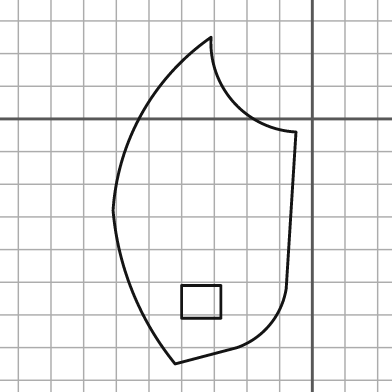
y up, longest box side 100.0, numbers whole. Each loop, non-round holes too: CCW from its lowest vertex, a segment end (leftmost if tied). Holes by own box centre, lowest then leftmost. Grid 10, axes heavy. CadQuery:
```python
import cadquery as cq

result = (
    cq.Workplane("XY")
    .moveTo(-42.0, -75.0)
    .lineTo(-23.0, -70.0)
    .threePointArc((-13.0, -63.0), (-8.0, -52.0))
    .lineTo(-5.0, -4.0)
    .threePointArc((-24.0, 5.0), (-31.0, 25.0))
    .threePointArc((-52.0, 2.0), (-61.0, -28.0))
    .threePointArc((-55.0, -53.0), (-42.0, -75.0))
    .close()
    .moveTo(-40.0, -61.0)
    .lineTo(-28.0, -61.0)
    .lineTo(-28.0, -51.0)
    .lineTo(-40.0, -51.0)
    .close()
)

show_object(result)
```